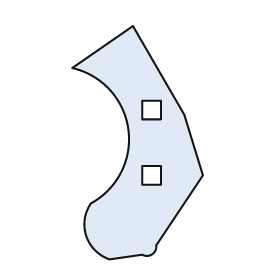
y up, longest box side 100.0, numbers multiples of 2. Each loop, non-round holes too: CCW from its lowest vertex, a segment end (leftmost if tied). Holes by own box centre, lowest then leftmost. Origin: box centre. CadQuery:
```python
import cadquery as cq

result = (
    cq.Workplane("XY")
    .moveTo(-12.0, -50.0)
    .lineTo(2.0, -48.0)
    .threePointArc((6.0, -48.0), (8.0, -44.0))
    .lineTo(28.0, -14.0)
    .lineTo(20.0, 12.0)
    .lineTo(-2.0, 50.0)
    .lineTo(-28.0, 32.0)
    .threePointArc((-4.0, 6.0), (-20.0, -26.0))
    .threePointArc((-22.0, -40.0), (-12.0, -50.0))
    .close()
    .moveTo(2.0, -18.0)
    .lineTo(10.0, -18.0)
    .lineTo(10.0, -10.0)
    .lineTo(2.0, -10.0)
    .close()
    .moveTo(2.0, 10.0)
    .lineTo(10.0, 10.0)
    .lineTo(10.0, 18.0)
    .lineTo(2.0, 18.0)
    .close()
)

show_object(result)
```